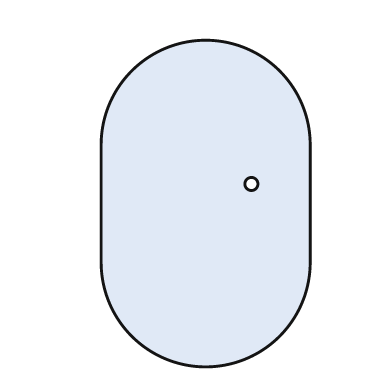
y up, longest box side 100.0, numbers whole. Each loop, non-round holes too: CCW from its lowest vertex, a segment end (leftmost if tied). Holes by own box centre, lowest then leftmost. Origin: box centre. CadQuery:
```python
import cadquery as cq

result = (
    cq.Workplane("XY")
    .moveTo(-32.0, -18.0)
    .threePointArc((0.0, -50.0), (32.0, -18.0))
    .lineTo(32.0, 18.0)
    .threePointArc((0.0, 50.0), (-32.0, 18.0))
    .close()
    .moveTo(14.0, 6.0)
    .circle(2.0)
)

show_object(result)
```